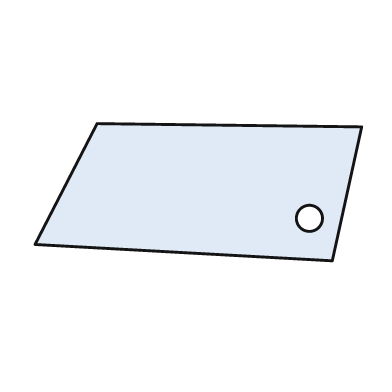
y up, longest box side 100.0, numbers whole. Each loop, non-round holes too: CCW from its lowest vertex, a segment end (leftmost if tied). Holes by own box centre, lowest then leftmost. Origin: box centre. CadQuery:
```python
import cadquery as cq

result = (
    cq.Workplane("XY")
    .moveTo(41.0, -21.0)
    .lineTo(50.0, 20.0)
    .lineTo(-31.0, 21.0)
    .lineTo(-50.0, -16.0)
    .close()
    .moveTo(34.0, -8.0)
    .circle(4.0)
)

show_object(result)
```